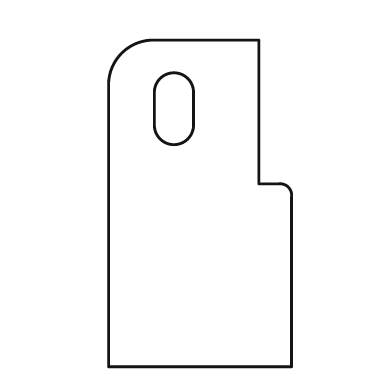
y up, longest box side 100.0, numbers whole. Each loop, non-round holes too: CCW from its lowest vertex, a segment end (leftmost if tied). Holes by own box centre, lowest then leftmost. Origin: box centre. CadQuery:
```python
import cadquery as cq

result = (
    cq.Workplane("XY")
    .moveTo(-28.0, -50.0)
    .lineTo(28.0, -50.0)
    .lineTo(28.0, 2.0)
    .threePointArc((27.0, 5.0), (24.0, 6.0))
    .lineTo(18.0, 6.0)
    .lineTo(18.0, 50.0)
    .lineTo(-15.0, 50.0)
    .threePointArc((-24.0, 46.0), (-28.0, 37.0))
    .close()
    .moveTo(-14.0, 24.0)
    .threePointArc((-8.0, 18.0), (-2.0, 24.0))
    .lineTo(-2.0, 34.0)
    .threePointArc((-8.0, 40.0), (-14.0, 34.0))
    .close()
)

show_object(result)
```